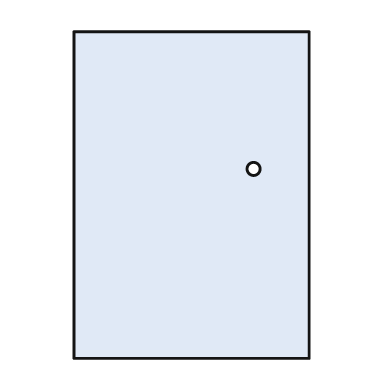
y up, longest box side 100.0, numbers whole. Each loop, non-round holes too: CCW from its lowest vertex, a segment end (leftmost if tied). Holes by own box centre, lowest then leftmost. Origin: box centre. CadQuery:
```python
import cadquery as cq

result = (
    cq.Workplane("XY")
    .moveTo(-36.0, -50.0)
    .lineTo(36.0, -50.0)
    .lineTo(36.0, 50.0)
    .lineTo(-36.0, 50.0)
    .close()
    .moveTo(19.0, 8.0)
    .circle(2.0)
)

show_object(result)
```